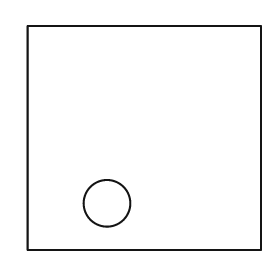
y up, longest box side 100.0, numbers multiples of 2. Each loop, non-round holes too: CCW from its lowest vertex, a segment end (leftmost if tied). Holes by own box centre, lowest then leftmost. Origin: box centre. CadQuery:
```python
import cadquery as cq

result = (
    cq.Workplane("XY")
    .moveTo(-50.0, -48.0)
    .lineTo(50.0, -48.0)
    .lineTo(50.0, 48.0)
    .lineTo(-50.0, 48.0)
    .close()
    .moveTo(-16.0, -28.0)
    .circle(10.0)
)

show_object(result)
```